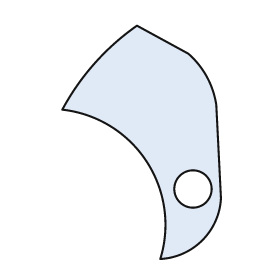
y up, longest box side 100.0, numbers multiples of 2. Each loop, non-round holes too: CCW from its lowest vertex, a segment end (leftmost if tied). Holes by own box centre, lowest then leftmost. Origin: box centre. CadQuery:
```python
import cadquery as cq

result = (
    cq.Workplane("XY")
    .moveTo(8.0, -50.0)
    .threePointArc((26.0, -42.0), (34.0, -24.0))
    .lineTo(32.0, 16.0)
    .threePointArc((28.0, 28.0), (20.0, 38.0))
    .lineTo(-2.0, 50.0)
    .threePointArc((-20.0, 34.0), (-34.0, 14.0))
    .threePointArc((2.0, -8.0), (8.0, -50.0))
    .close()
    .moveTo(22.0, -20.0)
    .circle(8.0)
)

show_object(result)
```